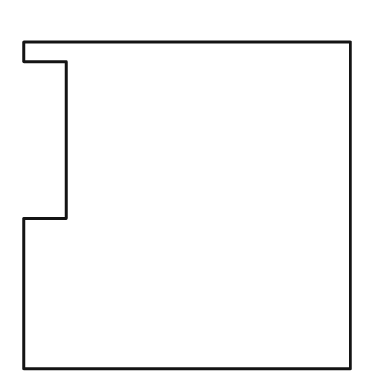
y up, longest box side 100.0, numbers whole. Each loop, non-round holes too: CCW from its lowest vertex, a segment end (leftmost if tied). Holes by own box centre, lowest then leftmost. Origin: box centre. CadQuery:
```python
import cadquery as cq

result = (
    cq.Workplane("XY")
    .moveTo(-50.0, -50.0)
    .lineTo(50.0, -50.0)
    .lineTo(50.0, 50.0)
    .lineTo(-50.0, 50.0)
    .lineTo(-50.0, 44.0)
    .lineTo(-37.0, 44.0)
    .lineTo(-37.0, -4.0)
    .lineTo(-50.0, -4.0)
    .close()
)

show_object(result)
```